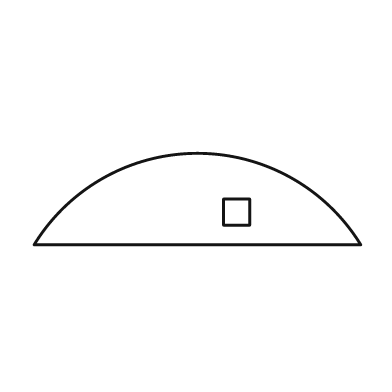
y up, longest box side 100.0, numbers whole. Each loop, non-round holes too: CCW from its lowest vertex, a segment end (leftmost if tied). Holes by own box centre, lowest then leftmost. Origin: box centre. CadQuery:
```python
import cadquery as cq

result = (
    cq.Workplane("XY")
    .moveTo(-50.0, -14.0)
    .lineTo(50.0, -14.0)
    .threePointArc((0.0, 14.0), (-50.0, -14.0))
    .close()
    .moveTo(8.0, -8.0)
    .lineTo(16.0, -8.0)
    .lineTo(16.0, 0.0)
    .lineTo(8.0, 0.0)
    .close()
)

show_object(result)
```